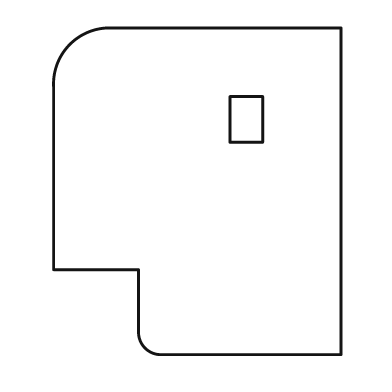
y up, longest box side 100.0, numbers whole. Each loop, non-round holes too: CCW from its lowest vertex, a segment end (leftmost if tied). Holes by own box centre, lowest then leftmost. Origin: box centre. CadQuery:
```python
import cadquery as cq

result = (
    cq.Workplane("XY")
    .moveTo(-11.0, -50.0)
    .lineTo(44.0, -50.0)
    .lineTo(44.0, 50.0)
    .lineTo(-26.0, 50.0)
    .threePointArc((-39.0, 45.0), (-44.0, 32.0))
    .lineTo(-44.0, -24.0)
    .lineTo(-18.0, -24.0)
    .lineTo(-18.0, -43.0)
    .threePointArc((-16.0, -48.0), (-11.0, -50.0))
    .close()
    .moveTo(10.0, 15.0)
    .lineTo(20.0, 15.0)
    .lineTo(20.0, 29.0)
    .lineTo(10.0, 29.0)
    .close()
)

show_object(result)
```